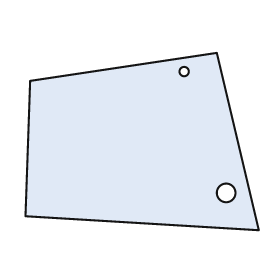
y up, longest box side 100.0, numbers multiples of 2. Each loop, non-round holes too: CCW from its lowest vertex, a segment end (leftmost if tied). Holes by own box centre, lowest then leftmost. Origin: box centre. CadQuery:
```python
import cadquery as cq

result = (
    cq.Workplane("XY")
    .moveTo(50.0, -38.0)
    .lineTo(32.0, 38.0)
    .lineTo(-48.0, 26.0)
    .lineTo(-50.0, -32.0)
    .close()
    .moveTo(36.0, -22.0)
    .circle(4.0)
    .moveTo(18.0, 30.0)
    .circle(2.0)
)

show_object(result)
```